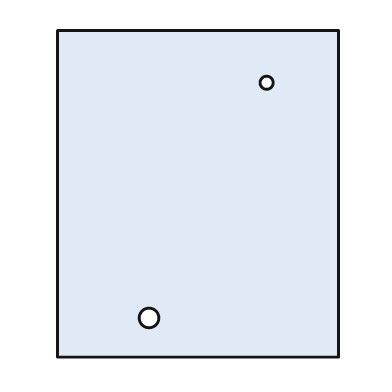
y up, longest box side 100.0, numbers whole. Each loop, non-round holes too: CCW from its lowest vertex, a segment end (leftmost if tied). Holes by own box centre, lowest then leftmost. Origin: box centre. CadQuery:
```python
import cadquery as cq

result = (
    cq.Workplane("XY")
    .moveTo(-43.0, -50.0)
    .lineTo(43.0, -50.0)
    .lineTo(43.0, 50.0)
    .lineTo(-43.0, 50.0)
    .close()
    .moveTo(-15.0, -38.0)
    .circle(3.0)
    .moveTo(21.0, 34.0)
    .circle(2.0)
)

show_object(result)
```